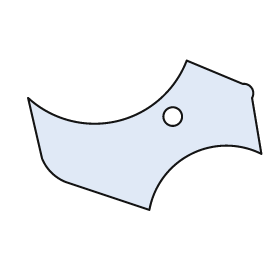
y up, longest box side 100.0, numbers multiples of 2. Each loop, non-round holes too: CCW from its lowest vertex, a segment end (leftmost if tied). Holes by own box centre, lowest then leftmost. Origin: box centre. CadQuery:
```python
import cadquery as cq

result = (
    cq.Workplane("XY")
    .moveTo(2.0, -32.0)
    .threePointArc((20.0, -8.0), (50.0, -8.0))
    .lineTo(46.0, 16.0)
    .threePointArc((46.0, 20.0), (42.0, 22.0))
    .lineTo(18.0, 32.0)
    .threePointArc((-12.0, 6.0), (-50.0, 16.0))
    .lineTo(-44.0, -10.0)
    .threePointArc((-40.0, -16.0), (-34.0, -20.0))
    .close()
    .moveTo(12.0, 8.0)
    .circle(4.0)
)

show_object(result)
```